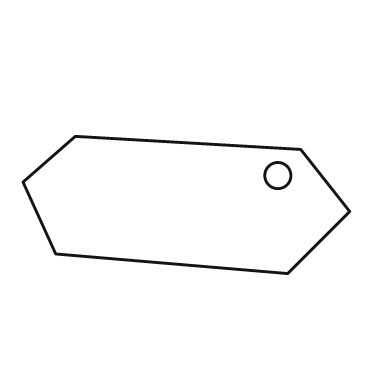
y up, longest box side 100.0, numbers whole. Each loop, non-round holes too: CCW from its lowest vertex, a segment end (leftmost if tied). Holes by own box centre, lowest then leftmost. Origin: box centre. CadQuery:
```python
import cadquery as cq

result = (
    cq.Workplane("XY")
    .moveTo(31.0, -21.0)
    .lineTo(50.0, -2.0)
    .lineTo(35.0, 17.0)
    .lineTo(-34.0, 21.0)
    .lineTo(-50.0, 7.0)
    .lineTo(-40.0, -15.0)
    .close()
    .moveTo(28.0, 9.0)
    .circle(4.0)
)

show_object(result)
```